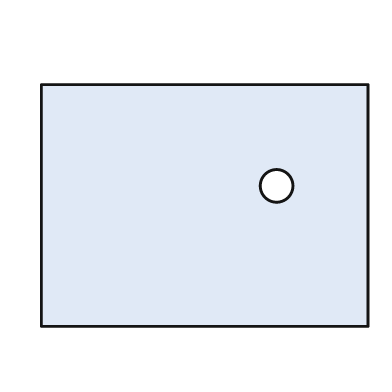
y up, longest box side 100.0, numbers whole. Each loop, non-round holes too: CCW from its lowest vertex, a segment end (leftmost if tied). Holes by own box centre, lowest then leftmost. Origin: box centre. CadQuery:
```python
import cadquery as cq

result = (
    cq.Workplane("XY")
    .moveTo(-50.0, -37.0)
    .lineTo(50.0, -37.0)
    .lineTo(50.0, 37.0)
    .lineTo(-50.0, 37.0)
    .close()
    .moveTo(22.0, 6.0)
    .circle(5.0)
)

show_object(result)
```